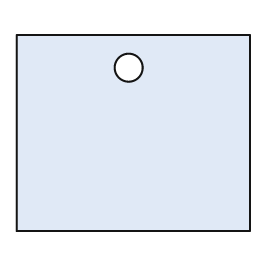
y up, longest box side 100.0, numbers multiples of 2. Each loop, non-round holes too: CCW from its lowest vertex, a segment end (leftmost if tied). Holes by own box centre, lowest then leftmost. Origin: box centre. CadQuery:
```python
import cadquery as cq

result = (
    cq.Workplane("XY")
    .moveTo(-50.0, -42.0)
    .lineTo(50.0, -42.0)
    .lineTo(50.0, 42.0)
    .lineTo(-50.0, 42.0)
    .close()
    .moveTo(-2.0, 28.0)
    .circle(6.0)
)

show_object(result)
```